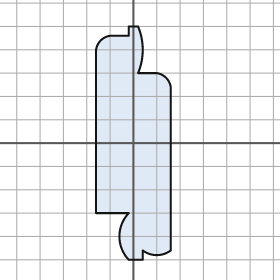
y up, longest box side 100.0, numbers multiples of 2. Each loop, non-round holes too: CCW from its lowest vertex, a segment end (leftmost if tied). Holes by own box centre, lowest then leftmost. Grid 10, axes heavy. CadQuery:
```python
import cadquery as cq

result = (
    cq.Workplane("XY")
    .moveTo(-2.0, -50.0)
    .lineTo(4.0, -50.0)
    .lineTo(4.0, -46.0)
    .threePointArc((10.0, -48.0), (16.0, -46.0))
    .lineTo(16.0, 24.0)
    .threePointArc((14.0, 28.0), (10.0, 30.0))
    .lineTo(2.0, 30.0)
    .threePointArc((4.0, 40.0), (2.0, 50.0))
    .lineTo(-2.0, 50.0)
    .lineTo(-2.0, 46.0)
    .lineTo(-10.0, 46.0)
    .threePointArc((-14.0, 44.0), (-16.0, 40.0))
    .lineTo(-16.0, -30.0)
    .lineTo(-2.0, -30.0)
    .threePointArc((-6.0, -40.0), (-2.0, -50.0))
    .close()
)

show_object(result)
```